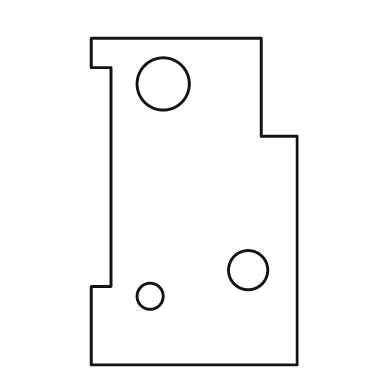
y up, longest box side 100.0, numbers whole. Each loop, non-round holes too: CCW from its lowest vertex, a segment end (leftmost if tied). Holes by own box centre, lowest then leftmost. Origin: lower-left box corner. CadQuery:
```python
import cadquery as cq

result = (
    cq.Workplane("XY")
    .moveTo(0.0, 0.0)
    .lineTo(63.0, 0.0)
    .lineTo(63.0, 70.0)
    .lineTo(52.0, 70.0)
    .lineTo(52.0, 100.0)
    .lineTo(0.0, 100.0)
    .lineTo(0.0, 91.0)
    .lineTo(6.0, 91.0)
    .lineTo(6.0, 24.0)
    .lineTo(0.0, 24.0)
    .close()
    .moveTo(18.0, 21.0)
    .circle(4.0)
    .moveTo(48.0, 29.0)
    .circle(6.0)
    .moveTo(22.0, 86.0)
    .circle(8.0)
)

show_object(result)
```